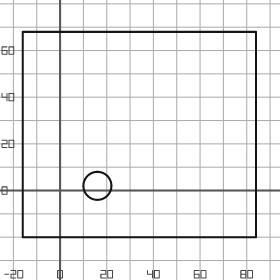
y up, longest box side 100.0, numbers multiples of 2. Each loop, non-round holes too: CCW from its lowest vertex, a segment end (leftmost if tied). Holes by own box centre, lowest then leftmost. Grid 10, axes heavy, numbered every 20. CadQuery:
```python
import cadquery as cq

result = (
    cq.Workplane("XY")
    .moveTo(-16.0, -20.0)
    .lineTo(84.0, -20.0)
    .lineTo(84.0, 68.0)
    .lineTo(-16.0, 68.0)
    .close()
    .moveTo(16.0, 2.0)
    .circle(6.0)
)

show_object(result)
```